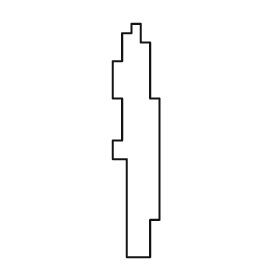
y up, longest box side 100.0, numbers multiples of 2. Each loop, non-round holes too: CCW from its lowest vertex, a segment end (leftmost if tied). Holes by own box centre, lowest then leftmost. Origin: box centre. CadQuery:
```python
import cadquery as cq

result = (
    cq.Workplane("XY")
    .moveTo(-4.0, -50.0)
    .lineTo(6.0, -50.0)
    .lineTo(6.0, -34.0)
    .lineTo(10.0, -34.0)
    .lineTo(10.0, 18.0)
    .lineTo(6.0, 18.0)
    .lineTo(6.0, 42.0)
    .lineTo(2.0, 42.0)
    .lineTo(2.0, 50.0)
    .lineTo(-2.0, 50.0)
    .lineTo(-2.0, 46.0)
    .lineTo(-6.0, 46.0)
    .lineTo(-6.0, 34.0)
    .lineTo(-10.0, 34.0)
    .lineTo(-10.0, 18.0)
    .lineTo(-6.0, 18.0)
    .lineTo(-6.0, 0.0)
    .lineTo(-10.0, 0.0)
    .lineTo(-10.0, -8.0)
    .lineTo(-4.0, -8.0)
    .close()
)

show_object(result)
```